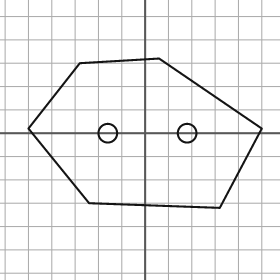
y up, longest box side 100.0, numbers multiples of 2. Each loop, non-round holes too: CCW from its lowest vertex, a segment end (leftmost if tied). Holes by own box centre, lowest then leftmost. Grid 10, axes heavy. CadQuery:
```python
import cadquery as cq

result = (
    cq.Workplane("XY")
    .moveTo(32.0, -32.0)
    .lineTo(50.0, 2.0)
    .lineTo(6.0, 32.0)
    .lineTo(-28.0, 30.0)
    .lineTo(-50.0, 2.0)
    .lineTo(-24.0, -30.0)
    .close()
    .moveTo(-16.0, 0.0)
    .circle(4.0)
    .moveTo(18.0, 0.0)
    .circle(4.0)
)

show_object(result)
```